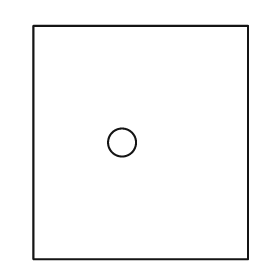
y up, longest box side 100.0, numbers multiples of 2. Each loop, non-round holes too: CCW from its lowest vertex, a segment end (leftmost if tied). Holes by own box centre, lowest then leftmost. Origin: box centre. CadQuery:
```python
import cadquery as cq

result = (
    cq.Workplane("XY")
    .moveTo(-46.0, -50.0)
    .lineTo(46.0, -50.0)
    .lineTo(46.0, 50.0)
    .lineTo(-46.0, 50.0)
    .close()
    .moveTo(-8.0, 0.0)
    .circle(6.0)
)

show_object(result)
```